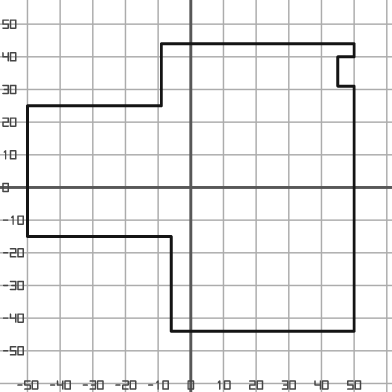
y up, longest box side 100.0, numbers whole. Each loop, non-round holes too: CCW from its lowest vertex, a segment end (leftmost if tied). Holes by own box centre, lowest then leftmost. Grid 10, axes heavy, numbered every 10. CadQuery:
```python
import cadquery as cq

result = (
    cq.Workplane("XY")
    .moveTo(-6.0, -44.0)
    .lineTo(50.0, -44.0)
    .lineTo(50.0, 31.0)
    .lineTo(45.0, 31.0)
    .lineTo(45.0, 40.0)
    .lineTo(50.0, 40.0)
    .lineTo(50.0, 44.0)
    .lineTo(-9.0, 44.0)
    .lineTo(-9.0, 25.0)
    .lineTo(-50.0, 25.0)
    .lineTo(-50.0, -15.0)
    .lineTo(-6.0, -15.0)
    .close()
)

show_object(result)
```